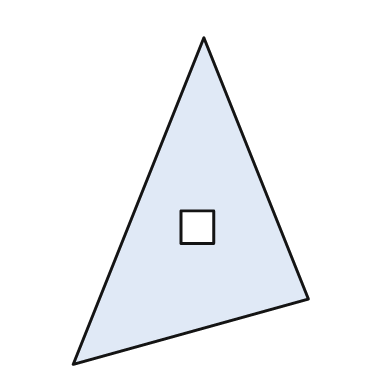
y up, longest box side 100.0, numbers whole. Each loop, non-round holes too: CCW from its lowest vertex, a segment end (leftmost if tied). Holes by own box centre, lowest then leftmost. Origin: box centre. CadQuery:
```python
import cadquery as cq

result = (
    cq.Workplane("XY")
    .moveTo(-36.0, -50.0)
    .lineTo(36.0, -30.0)
    .lineTo(4.0, 50.0)
    .close()
    .moveTo(-3.0, -13.0)
    .lineTo(7.0, -13.0)
    .lineTo(7.0, -3.0)
    .lineTo(-3.0, -3.0)
    .close()
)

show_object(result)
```